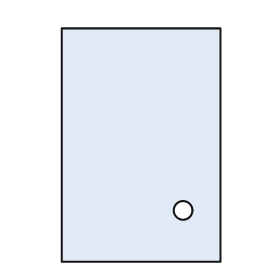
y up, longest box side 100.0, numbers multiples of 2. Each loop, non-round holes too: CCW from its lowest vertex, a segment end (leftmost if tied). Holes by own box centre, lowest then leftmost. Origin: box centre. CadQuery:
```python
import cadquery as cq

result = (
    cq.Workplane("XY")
    .moveTo(-34.0, -50.0)
    .lineTo(34.0, -50.0)
    .lineTo(34.0, 50.0)
    .lineTo(-34.0, 50.0)
    .close()
    .moveTo(18.0, -28.0)
    .circle(4.0)
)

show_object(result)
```